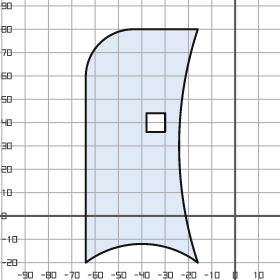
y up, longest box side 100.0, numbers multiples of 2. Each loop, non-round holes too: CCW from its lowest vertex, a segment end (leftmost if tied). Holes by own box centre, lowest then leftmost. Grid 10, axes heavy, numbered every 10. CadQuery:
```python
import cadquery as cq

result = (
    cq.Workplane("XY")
    .moveTo(-64.0, -20.0)
    .threePointArc((-40.0, -12.0), (-16.0, -20.0))
    .threePointArc((-24.0, 30.0), (-16.0, 80.0))
    .lineTo(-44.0, 80.0)
    .threePointArc((-58.0, 74.0), (-64.0, 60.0))
    .close()
    .moveTo(-38.0, 36.0)
    .lineTo(-30.0, 36.0)
    .lineTo(-30.0, 44.0)
    .lineTo(-38.0, 44.0)
    .close()
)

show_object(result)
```